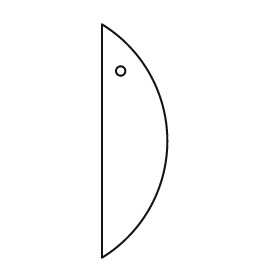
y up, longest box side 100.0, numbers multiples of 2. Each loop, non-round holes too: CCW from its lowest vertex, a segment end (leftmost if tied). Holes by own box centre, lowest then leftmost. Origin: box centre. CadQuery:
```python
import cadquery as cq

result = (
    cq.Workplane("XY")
    .moveTo(-14.0, -50.0)
    .threePointArc((14.0, 0.0), (-14.0, 50.0))
    .close()
    .moveTo(-6.0, 30.0)
    .circle(2.0)
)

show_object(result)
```